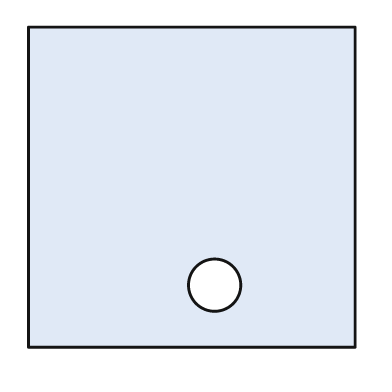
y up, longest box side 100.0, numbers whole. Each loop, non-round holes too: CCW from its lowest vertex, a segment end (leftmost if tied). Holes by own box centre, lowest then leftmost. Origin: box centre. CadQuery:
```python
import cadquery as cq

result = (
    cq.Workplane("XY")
    .moveTo(-50.0, -49.0)
    .lineTo(50.0, -49.0)
    .lineTo(50.0, 49.0)
    .lineTo(-50.0, 49.0)
    .close()
    .moveTo(7.0, -30.0)
    .circle(8.0)
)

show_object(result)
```